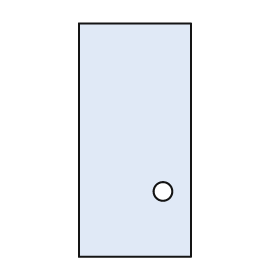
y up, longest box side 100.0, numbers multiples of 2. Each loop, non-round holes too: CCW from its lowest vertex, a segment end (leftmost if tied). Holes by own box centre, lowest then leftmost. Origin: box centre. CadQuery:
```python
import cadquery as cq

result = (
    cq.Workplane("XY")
    .moveTo(-24.0, -50.0)
    .lineTo(24.0, -50.0)
    .lineTo(24.0, 50.0)
    .lineTo(-24.0, 50.0)
    .close()
    .moveTo(12.0, -22.0)
    .circle(4.0)
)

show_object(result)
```